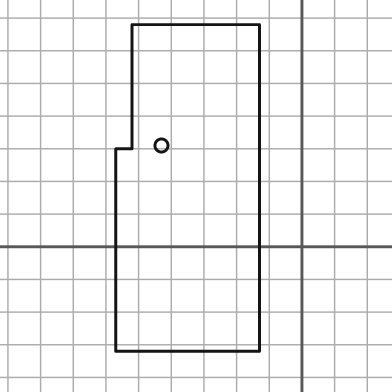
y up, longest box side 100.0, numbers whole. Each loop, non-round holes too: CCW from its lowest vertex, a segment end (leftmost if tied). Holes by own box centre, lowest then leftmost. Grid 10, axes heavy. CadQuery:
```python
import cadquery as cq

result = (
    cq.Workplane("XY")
    .moveTo(-57.0, -32.0)
    .lineTo(-13.0, -32.0)
    .lineTo(-13.0, 68.0)
    .lineTo(-52.0, 68.0)
    .lineTo(-52.0, 30.0)
    .lineTo(-57.0, 30.0)
    .close()
    .moveTo(-43.0, 31.0)
    .circle(2.0)
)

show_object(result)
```